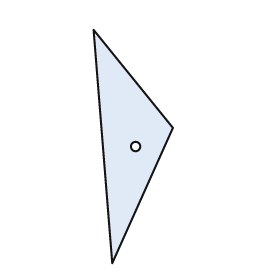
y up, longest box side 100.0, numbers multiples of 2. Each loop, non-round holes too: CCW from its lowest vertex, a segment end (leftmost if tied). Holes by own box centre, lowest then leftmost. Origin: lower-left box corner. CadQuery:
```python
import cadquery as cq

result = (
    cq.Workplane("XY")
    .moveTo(8.0, 0.0)
    .lineTo(34.0, 58.0)
    .lineTo(0.0, 100.0)
    .close()
    .moveTo(18.0, 50.0)
    .circle(2.0)
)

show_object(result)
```